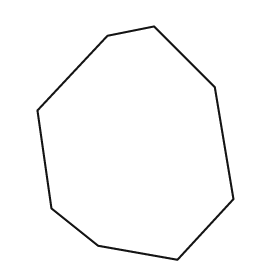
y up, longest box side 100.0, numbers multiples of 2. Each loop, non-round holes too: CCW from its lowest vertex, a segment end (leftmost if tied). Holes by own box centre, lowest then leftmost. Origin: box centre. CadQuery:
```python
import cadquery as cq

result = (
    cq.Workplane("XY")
    .moveTo(18.0, -50.0)
    .lineTo(42.0, -24.0)
    .lineTo(34.0, 24.0)
    .lineTo(8.0, 50.0)
    .lineTo(-12.0, 46.0)
    .lineTo(-42.0, 14.0)
    .lineTo(-36.0, -28.0)
    .lineTo(-16.0, -44.0)
    .close()
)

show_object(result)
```